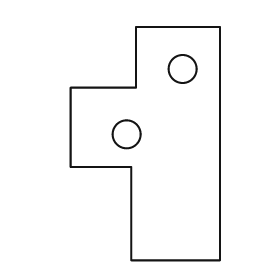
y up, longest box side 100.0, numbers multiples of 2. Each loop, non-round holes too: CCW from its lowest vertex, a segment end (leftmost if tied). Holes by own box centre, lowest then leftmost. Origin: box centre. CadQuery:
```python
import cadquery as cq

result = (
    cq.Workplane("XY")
    .moveTo(-6.0, -50.0)
    .lineTo(32.0, -50.0)
    .lineTo(32.0, 50.0)
    .lineTo(-4.0, 50.0)
    .lineTo(-4.0, 24.0)
    .lineTo(-32.0, 24.0)
    .lineTo(-32.0, -10.0)
    .lineTo(-6.0, -10.0)
    .close()
    .moveTo(-8.0, 4.0)
    .circle(6.0)
    .moveTo(16.0, 32.0)
    .circle(6.0)
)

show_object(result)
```